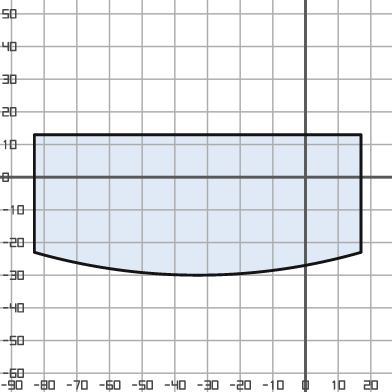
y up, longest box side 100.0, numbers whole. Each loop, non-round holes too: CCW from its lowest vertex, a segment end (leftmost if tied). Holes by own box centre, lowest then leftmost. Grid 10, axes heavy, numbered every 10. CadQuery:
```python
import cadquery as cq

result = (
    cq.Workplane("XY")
    .moveTo(-83.0, -23.0)
    .threePointArc((-33.0, -30.0), (17.0, -23.0))
    .lineTo(17.0, 13.0)
    .lineTo(-83.0, 13.0)
    .close()
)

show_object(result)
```